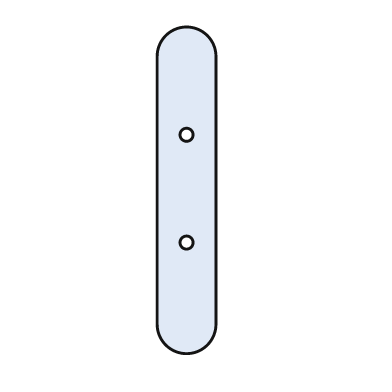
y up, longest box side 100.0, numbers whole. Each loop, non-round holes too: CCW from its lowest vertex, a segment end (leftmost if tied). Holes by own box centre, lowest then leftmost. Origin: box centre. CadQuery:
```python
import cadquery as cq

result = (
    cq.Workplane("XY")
    .moveTo(-9.0, -41.0)
    .threePointArc((0.0, -50.0), (9.0, -41.0))
    .lineTo(9.0, 41.0)
    .threePointArc((0.0, 50.0), (-9.0, 41.0))
    .close()
    .moveTo(0.0, -16.0)
    .circle(2.0)
    .moveTo(0.0, 17.0)
    .circle(2.0)
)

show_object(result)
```